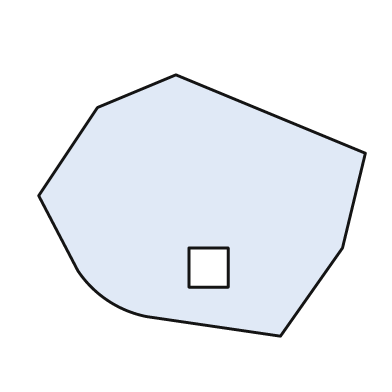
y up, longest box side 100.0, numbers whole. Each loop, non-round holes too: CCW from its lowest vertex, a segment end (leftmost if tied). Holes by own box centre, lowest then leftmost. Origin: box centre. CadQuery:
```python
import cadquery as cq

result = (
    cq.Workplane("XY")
    .moveTo(24.0, -40.0)
    .lineTo(43.0, -13.0)
    .lineTo(50.0, 16.0)
    .lineTo(-8.0, 40.0)
    .lineTo(-32.0, 30.0)
    .lineTo(-50.0, 3.0)
    .lineTo(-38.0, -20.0)
    .threePointArc((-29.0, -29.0), (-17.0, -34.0))
    .close()
    .moveTo(-4.0, -25.0)
    .lineTo(8.0, -25.0)
    .lineTo(8.0, -13.0)
    .lineTo(-4.0, -13.0)
    .close()
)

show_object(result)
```